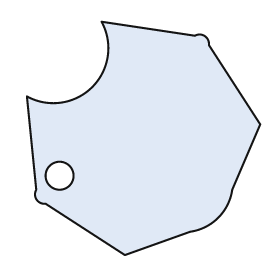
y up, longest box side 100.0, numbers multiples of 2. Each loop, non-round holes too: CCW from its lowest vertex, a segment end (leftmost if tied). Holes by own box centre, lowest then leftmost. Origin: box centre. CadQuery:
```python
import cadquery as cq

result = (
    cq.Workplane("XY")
    .moveTo(-8.0, -50.0)
    .lineTo(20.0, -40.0)
    .threePointArc((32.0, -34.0), (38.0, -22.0))
    .lineTo(50.0, 6.0)
    .lineTo(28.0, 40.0)
    .threePointArc((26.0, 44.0), (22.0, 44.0))
    .lineTo(-18.0, 50.0)
    .threePointArc((-22.0, 22.0), (-50.0, 18.0))
    .lineTo(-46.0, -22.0)
    .threePointArc((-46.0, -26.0), (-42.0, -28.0))
    .close()
    .moveTo(-36.0, -16.0)
    .circle(6.0)
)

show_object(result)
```